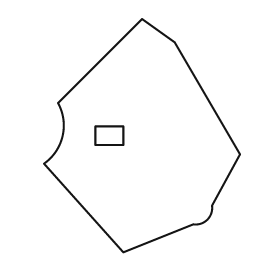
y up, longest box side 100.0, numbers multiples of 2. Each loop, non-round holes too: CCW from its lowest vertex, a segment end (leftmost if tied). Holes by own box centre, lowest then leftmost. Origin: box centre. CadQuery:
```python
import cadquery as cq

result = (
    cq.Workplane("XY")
    .moveTo(-8.0, -50.0)
    .lineTo(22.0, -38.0)
    .threePointArc((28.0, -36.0), (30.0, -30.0))
    .lineTo(42.0, -8.0)
    .lineTo(14.0, 40.0)
    .lineTo(0.0, 50.0)
    .lineTo(-36.0, 14.0)
    .threePointArc((-34.0, 0.0), (-42.0, -12.0))
    .close()
    .moveTo(-20.0, -4.0)
    .lineTo(-8.0, -4.0)
    .lineTo(-8.0, 4.0)
    .lineTo(-20.0, 4.0)
    .close()
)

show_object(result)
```